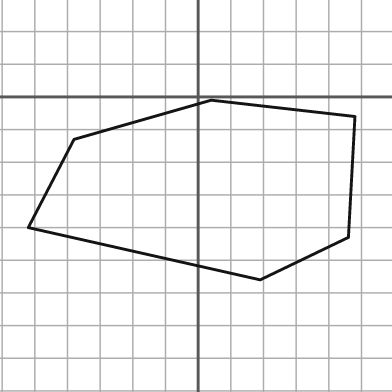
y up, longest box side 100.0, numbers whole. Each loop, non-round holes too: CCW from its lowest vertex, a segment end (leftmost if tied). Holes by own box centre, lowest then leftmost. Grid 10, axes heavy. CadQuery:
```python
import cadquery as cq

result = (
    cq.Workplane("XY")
    .moveTo(19.0, -56.0)
    .lineTo(46.0, -43.0)
    .lineTo(48.0, -6.0)
    .lineTo(4.0, -1.0)
    .lineTo(-38.0, -13.0)
    .lineTo(-52.0, -40.0)
    .close()
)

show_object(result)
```